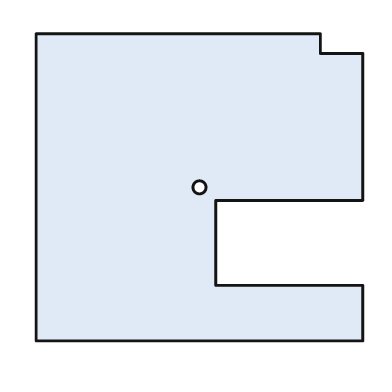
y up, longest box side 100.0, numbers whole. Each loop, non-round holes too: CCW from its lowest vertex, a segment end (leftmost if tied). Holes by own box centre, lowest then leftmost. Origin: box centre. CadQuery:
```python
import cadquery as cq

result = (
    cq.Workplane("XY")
    .moveTo(-50.0, -47.0)
    .lineTo(50.0, -47.0)
    .lineTo(50.0, -30.0)
    .lineTo(5.0, -30.0)
    .lineTo(5.0, -4.0)
    .lineTo(50.0, -4.0)
    .lineTo(50.0, 41.0)
    .lineTo(37.0, 41.0)
    .lineTo(37.0, 47.0)
    .lineTo(-50.0, 47.0)
    .close()
    .moveTo(0.0, 0.0)
    .circle(2.0)
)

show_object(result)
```